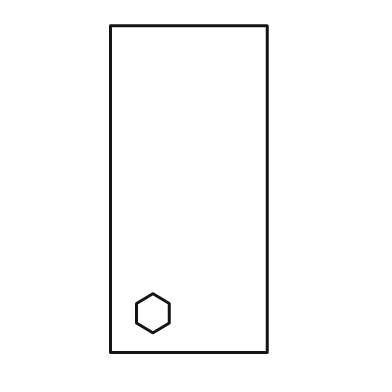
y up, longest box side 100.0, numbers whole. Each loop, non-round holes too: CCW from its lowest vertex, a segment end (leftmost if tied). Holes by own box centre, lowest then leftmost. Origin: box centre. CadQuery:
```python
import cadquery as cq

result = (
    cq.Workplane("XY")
    .moveTo(-24.0, -50.0)
    .lineTo(24.0, -50.0)
    .lineTo(24.0, 50.0)
    .lineTo(-24.0, 50.0)
    .close()
    .moveTo(-11.0, -44.0)
    .lineTo(-6.0, -41.0)
    .lineTo(-6.0, -35.0)
    .lineTo(-11.0, -32.0)
    .lineTo(-16.0, -35.0)
    .lineTo(-16.0, -41.0)
    .close()
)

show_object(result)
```